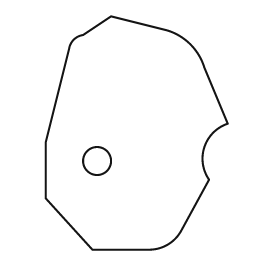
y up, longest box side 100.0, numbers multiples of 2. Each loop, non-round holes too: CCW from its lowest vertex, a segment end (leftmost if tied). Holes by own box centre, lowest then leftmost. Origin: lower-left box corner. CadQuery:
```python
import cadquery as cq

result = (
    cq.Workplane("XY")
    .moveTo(20.0, 0.0)
    .lineTo(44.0, 0.0)
    .threePointArc((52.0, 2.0), (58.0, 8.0))
    .lineTo(70.0, 30.0)
    .threePointArc((68.0, 44.0), (78.0, 54.0))
    .lineTo(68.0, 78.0)
    .threePointArc((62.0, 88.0), (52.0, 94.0))
    .lineTo(28.0, 100.0)
    .lineTo(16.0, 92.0)
    .threePointArc((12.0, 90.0), (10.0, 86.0))
    .lineTo(0.0, 46.0)
    .lineTo(0.0, 22.0)
    .close()
    .moveTo(22.0, 38.0)
    .circle(6.0)
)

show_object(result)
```